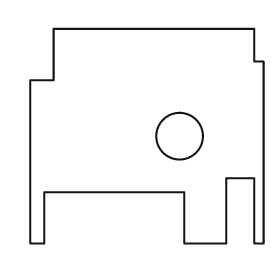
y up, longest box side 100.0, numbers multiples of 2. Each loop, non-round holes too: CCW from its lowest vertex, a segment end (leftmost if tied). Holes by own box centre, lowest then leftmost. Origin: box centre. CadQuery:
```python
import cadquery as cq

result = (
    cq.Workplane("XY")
    .moveTo(-50.0, -46.0)
    .lineTo(-44.0, -46.0)
    .lineTo(-44.0, -24.0)
    .lineTo(16.0, -24.0)
    .lineTo(16.0, -46.0)
    .lineTo(34.0, -46.0)
    .lineTo(34.0, -18.0)
    .lineTo(46.0, -18.0)
    .lineTo(46.0, -46.0)
    .lineTo(50.0, -46.0)
    .lineTo(50.0, 32.0)
    .lineTo(46.0, 32.0)
    .lineTo(46.0, 46.0)
    .lineTo(-40.0, 46.0)
    .lineTo(-40.0, 24.0)
    .lineTo(-50.0, 24.0)
    .close()
    .moveTo(14.0, 0.0)
    .circle(10.0)
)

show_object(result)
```